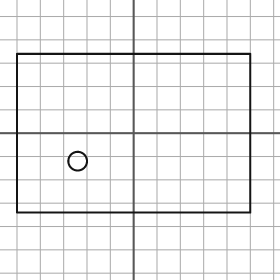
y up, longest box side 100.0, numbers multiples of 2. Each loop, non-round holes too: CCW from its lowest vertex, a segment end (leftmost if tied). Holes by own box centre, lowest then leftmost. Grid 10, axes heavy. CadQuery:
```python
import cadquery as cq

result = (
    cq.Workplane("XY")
    .moveTo(-50.0, -34.0)
    .lineTo(50.0, -34.0)
    .lineTo(50.0, 34.0)
    .lineTo(-50.0, 34.0)
    .close()
    .moveTo(-24.0, -12.0)
    .circle(4.0)
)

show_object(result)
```